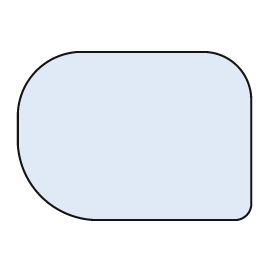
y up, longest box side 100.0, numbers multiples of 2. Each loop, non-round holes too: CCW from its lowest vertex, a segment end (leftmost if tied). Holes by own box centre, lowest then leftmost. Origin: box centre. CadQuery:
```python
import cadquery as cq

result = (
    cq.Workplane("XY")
    .moveTo(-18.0, -36.0)
    .lineTo(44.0, -36.0)
    .threePointArc((48.0, -34.0), (50.0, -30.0))
    .lineTo(50.0, 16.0)
    .threePointArc((44.0, 30.0), (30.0, 36.0))
    .lineTo(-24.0, 36.0)
    .threePointArc((-42.0, 28.0), (-50.0, 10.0))
    .lineTo(-50.0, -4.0)
    .threePointArc((-40.0, -26.0), (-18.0, -36.0))
    .close()
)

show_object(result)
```